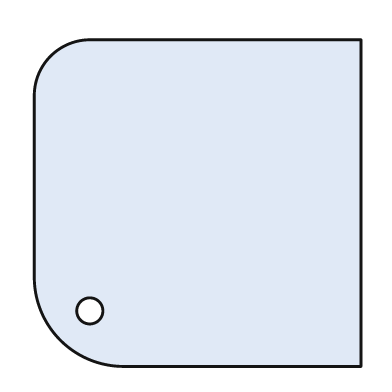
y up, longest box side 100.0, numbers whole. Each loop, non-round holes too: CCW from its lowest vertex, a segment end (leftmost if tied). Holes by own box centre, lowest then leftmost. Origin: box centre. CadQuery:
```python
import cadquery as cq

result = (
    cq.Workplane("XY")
    .moveTo(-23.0, -50.0)
    .lineTo(50.0, -50.0)
    .lineTo(50.0, 50.0)
    .lineTo(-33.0, 50.0)
    .threePointArc((-45.0, 45.0), (-50.0, 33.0))
    .lineTo(-50.0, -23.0)
    .threePointArc((-42.0, -42.0), (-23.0, -50.0))
    .close()
    .moveTo(-33.0, -33.0)
    .circle(4.0)
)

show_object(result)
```